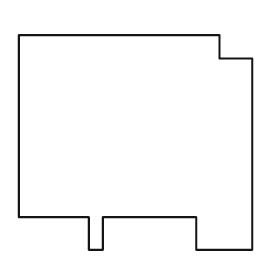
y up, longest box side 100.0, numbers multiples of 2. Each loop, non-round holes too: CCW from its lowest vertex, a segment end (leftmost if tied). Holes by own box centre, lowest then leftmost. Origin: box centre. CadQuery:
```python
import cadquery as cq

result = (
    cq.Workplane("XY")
    .moveTo(-20.0, -46.0)
    .lineTo(-14.0, -46.0)
    .lineTo(-14.0, -32.0)
    .lineTo(26.0, -32.0)
    .lineTo(26.0, -46.0)
    .lineTo(50.0, -46.0)
    .lineTo(50.0, 36.0)
    .lineTo(36.0, 36.0)
    .lineTo(36.0, 46.0)
    .lineTo(-50.0, 46.0)
    .lineTo(-50.0, -32.0)
    .lineTo(-20.0, -32.0)
    .close()
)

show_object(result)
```